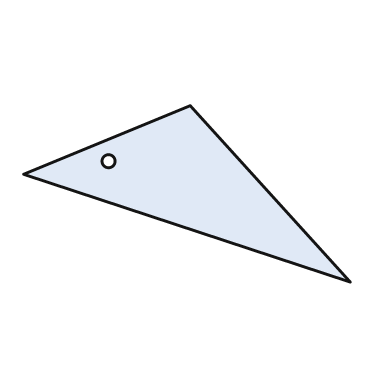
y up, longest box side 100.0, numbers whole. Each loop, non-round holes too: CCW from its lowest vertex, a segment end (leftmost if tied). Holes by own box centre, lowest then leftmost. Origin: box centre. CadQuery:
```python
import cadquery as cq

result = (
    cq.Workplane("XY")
    .moveTo(50.0, -27.0)
    .lineTo(1.0, 27.0)
    .lineTo(-50.0, 6.0)
    .close()
    .moveTo(-24.0, 10.0)
    .circle(2.0)
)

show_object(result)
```